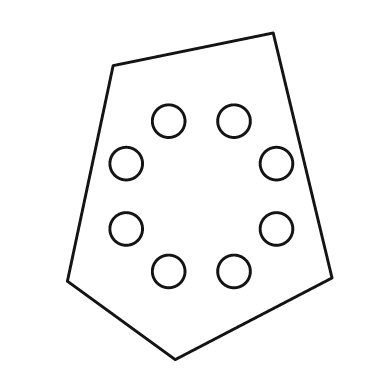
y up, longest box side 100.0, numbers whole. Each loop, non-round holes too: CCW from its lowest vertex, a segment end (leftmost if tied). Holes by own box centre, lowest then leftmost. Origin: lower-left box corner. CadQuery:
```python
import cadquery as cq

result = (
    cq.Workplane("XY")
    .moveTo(33.0, 0.0)
    .lineTo(81.0, 25.0)
    .lineTo(63.0, 100.0)
    .lineTo(14.0, 90.0)
    .lineTo(0.0, 24.0)
    .close()
    .moveTo(31.0, 27.0)
    .circle(5.0)
    .moveTo(51.0, 27.0)
    .circle(5.0)
    .moveTo(18.0, 40.0)
    .circle(5.0)
    .moveTo(64.0, 40.0)
    .circle(5.0)
    .moveTo(18.0, 60.0)
    .circle(5.0)
    .moveTo(64.0, 60.0)
    .circle(5.0)
    .moveTo(31.0, 73.0)
    .circle(5.0)
    .moveTo(51.0, 73.0)
    .circle(5.0)
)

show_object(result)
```